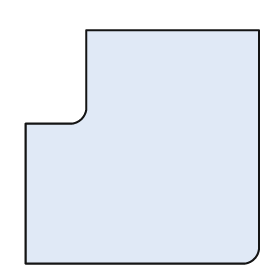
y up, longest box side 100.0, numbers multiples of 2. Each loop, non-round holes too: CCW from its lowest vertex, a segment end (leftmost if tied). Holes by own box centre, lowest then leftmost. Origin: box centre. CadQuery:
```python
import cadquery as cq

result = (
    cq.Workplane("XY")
    .moveTo(-50.0, -50.0)
    .lineTo(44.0, -50.0)
    .threePointArc((48.0, -48.0), (50.0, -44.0))
    .lineTo(50.0, 50.0)
    .lineTo(-24.0, 50.0)
    .lineTo(-24.0, 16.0)
    .threePointArc((-26.0, 12.0), (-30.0, 10.0))
    .lineTo(-50.0, 10.0)
    .close()
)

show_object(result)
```